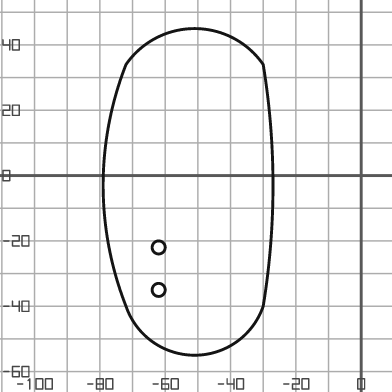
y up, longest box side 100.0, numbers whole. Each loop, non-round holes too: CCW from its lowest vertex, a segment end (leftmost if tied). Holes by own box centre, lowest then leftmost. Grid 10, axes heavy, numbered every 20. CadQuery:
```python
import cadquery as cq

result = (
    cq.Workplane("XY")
    .moveTo(-72.0, -40.0)
    .threePointArc((-51.0, -55.0), (-30.0, -40.0))
    .threePointArc((-27.0, -3.0), (-30.0, 34.0))
    .threePointArc((-51.0, 45.0), (-72.0, 34.0))
    .threePointArc((-79.0, -3.0), (-72.0, -40.0))
    .close()
    .moveTo(-62.0, -35.0)
    .circle(2.0)
    .moveTo(-62.0, -22.0)
    .circle(2.0)
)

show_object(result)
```